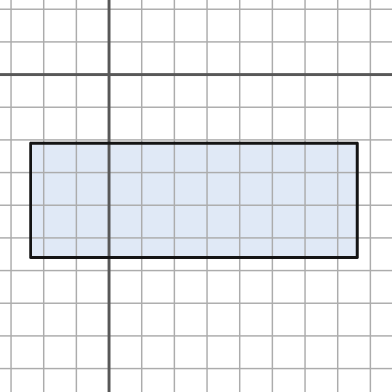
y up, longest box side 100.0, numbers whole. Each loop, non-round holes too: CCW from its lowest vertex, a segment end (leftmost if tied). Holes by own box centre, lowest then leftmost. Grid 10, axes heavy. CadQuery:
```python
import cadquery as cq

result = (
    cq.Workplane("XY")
    .moveTo(-24.0, -56.0)
    .lineTo(76.0, -56.0)
    .lineTo(76.0, -21.0)
    .lineTo(-24.0, -21.0)
    .close()
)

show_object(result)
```